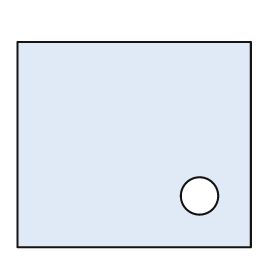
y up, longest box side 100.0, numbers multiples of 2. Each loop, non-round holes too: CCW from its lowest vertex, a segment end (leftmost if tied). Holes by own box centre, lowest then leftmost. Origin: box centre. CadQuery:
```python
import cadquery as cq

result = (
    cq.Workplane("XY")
    .moveTo(-50.0, -44.0)
    .lineTo(50.0, -44.0)
    .lineTo(50.0, 44.0)
    .lineTo(-50.0, 44.0)
    .close()
    .moveTo(28.0, -22.0)
    .circle(8.0)
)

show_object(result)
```